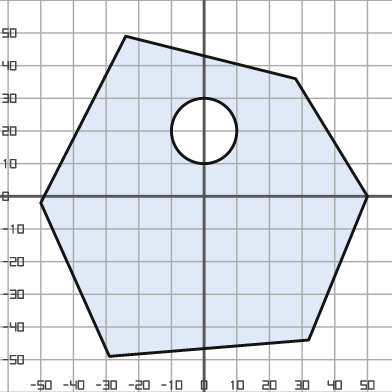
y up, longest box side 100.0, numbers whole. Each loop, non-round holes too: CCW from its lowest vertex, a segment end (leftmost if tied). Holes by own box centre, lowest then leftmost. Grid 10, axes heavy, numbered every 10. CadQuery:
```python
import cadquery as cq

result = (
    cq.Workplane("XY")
    .moveTo(-29.0, -49.0)
    .lineTo(32.0, -44.0)
    .lineTo(50.0, 0.0)
    .lineTo(28.0, 36.0)
    .lineTo(-24.0, 49.0)
    .lineTo(-50.0, -2.0)
    .close()
    .moveTo(0.0, 20.0)
    .circle(10.0)
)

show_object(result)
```